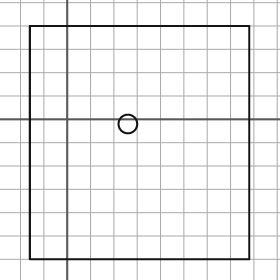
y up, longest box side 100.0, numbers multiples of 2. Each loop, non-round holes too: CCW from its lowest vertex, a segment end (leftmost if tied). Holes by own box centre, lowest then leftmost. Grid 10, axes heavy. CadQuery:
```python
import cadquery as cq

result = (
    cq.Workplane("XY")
    .moveTo(-16.0, -60.0)
    .lineTo(78.0, -60.0)
    .lineTo(78.0, 40.0)
    .lineTo(-16.0, 40.0)
    .close()
    .moveTo(26.0, -2.0)
    .circle(4.0)
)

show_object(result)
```